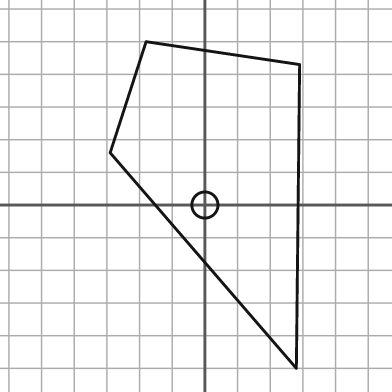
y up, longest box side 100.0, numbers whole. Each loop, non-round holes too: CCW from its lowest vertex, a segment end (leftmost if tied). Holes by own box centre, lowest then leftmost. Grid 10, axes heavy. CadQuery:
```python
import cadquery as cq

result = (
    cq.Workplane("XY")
    .moveTo(28.0, -50.0)
    .lineTo(29.0, 43.0)
    .lineTo(-18.0, 50.0)
    .lineTo(-29.0, 16.0)
    .close()
    .moveTo(0.0, 0.0)
    .circle(4.0)
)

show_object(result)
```